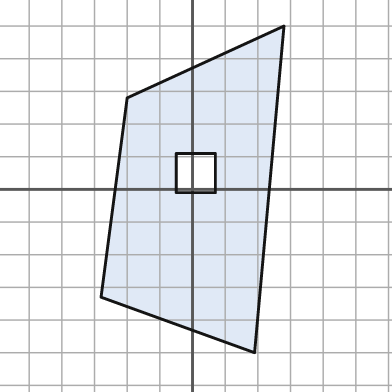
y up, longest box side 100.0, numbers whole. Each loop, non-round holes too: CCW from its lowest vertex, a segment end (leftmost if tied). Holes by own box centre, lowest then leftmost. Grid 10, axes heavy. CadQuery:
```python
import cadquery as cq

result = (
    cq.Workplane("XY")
    .moveTo(19.0, -50.0)
    .lineTo(28.0, 50.0)
    .lineTo(-20.0, 28.0)
    .lineTo(-28.0, -33.0)
    .close()
    .moveTo(-5.0, -1.0)
    .lineTo(7.0, -1.0)
    .lineTo(7.0, 11.0)
    .lineTo(-5.0, 11.0)
    .close()
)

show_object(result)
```